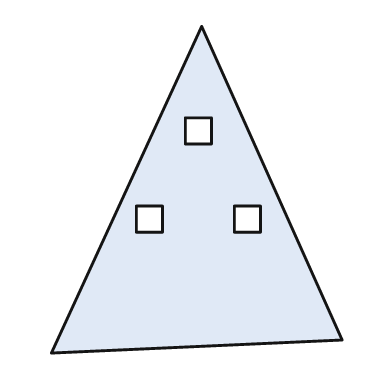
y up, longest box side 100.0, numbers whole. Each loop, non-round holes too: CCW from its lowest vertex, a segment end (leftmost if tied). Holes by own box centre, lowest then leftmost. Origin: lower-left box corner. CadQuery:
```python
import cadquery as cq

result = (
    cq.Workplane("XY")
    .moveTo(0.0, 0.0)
    .lineTo(89.0, 4.0)
    .lineTo(46.0, 100.0)
    .close()
    .moveTo(26.0, 37.0)
    .lineTo(34.0, 37.0)
    .lineTo(34.0, 45.0)
    .lineTo(26.0, 45.0)
    .close()
    .moveTo(56.0, 37.0)
    .lineTo(64.0, 37.0)
    .lineTo(64.0, 45.0)
    .lineTo(56.0, 45.0)
    .close()
    .moveTo(41.0, 64.0)
    .lineTo(49.0, 64.0)
    .lineTo(49.0, 72.0)
    .lineTo(41.0, 72.0)
    .close()
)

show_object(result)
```